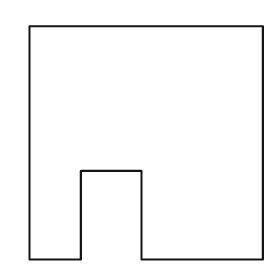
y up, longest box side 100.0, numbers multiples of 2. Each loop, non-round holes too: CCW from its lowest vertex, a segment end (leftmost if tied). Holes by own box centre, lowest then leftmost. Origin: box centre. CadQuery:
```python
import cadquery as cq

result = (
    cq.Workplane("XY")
    .moveTo(-50.0, -50.0)
    .lineTo(-28.0, -50.0)
    .lineTo(-28.0, -12.0)
    .lineTo(-2.0, -12.0)
    .lineTo(-2.0, -50.0)
    .lineTo(50.0, -50.0)
    .lineTo(50.0, 50.0)
    .lineTo(-50.0, 50.0)
    .close()
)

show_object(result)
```